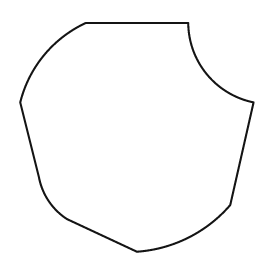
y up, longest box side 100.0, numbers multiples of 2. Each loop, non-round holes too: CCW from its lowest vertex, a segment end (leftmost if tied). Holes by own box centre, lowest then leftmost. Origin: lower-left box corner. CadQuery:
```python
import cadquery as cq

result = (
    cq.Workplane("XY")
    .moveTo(50.0, 0.0)
    .threePointArc((72.0, 6.0), (90.0, 20.0))
    .lineTo(100.0, 64.0)
    .threePointArc((80.0, 76.0), (72.0, 98.0))
    .lineTo(28.0, 98.0)
    .threePointArc((10.0, 84.0), (0.0, 64.0))
    .lineTo(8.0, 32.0)
    .threePointArc((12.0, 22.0), (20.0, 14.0))
    .close()
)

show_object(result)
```